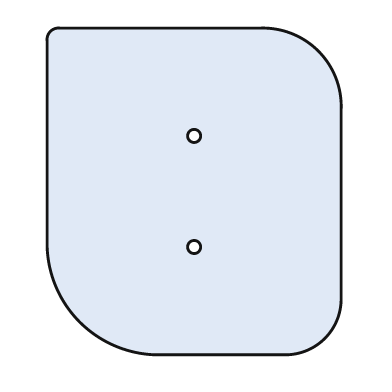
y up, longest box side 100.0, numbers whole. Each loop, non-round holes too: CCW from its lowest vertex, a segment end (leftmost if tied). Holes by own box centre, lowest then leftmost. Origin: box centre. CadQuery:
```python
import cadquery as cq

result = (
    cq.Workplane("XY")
    .moveTo(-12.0, -50.0)
    .lineTo(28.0, -50.0)
    .threePointArc((40.0, -45.0), (45.0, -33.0))
    .lineTo(45.0, 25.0)
    .threePointArc((38.0, 43.0), (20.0, 50.0))
    .lineTo(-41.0, 50.0)
    .threePointArc((-44.0, 49.0), (-45.0, 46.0))
    .lineTo(-45.0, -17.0)
    .threePointArc((-35.0, -40.0), (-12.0, -50.0))
    .close()
    .moveTo(0.0, -17.0)
    .circle(2.0)
    .moveTo(0.0, 17.0)
    .circle(2.0)
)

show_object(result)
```